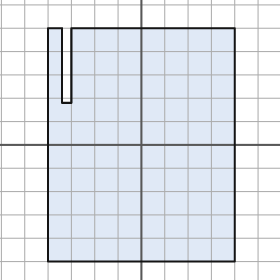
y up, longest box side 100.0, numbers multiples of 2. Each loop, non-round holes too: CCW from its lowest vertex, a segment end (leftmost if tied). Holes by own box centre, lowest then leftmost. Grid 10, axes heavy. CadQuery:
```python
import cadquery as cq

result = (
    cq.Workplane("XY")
    .moveTo(-40.0, -50.0)
    .lineTo(40.0, -50.0)
    .lineTo(40.0, 50.0)
    .lineTo(-30.0, 50.0)
    .lineTo(-30.0, 18.0)
    .lineTo(-34.0, 18.0)
    .lineTo(-34.0, 50.0)
    .lineTo(-40.0, 50.0)
    .close()
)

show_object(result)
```